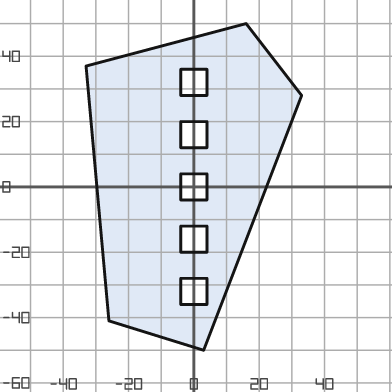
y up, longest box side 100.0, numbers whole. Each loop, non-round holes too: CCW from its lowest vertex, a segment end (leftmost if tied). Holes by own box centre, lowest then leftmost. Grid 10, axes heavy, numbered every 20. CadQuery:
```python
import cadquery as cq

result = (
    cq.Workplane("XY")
    .moveTo(3.0, -50.0)
    .lineTo(33.0, 28.0)
    .lineTo(16.0, 50.0)
    .lineTo(-33.0, 37.0)
    .lineTo(-26.0, -41.0)
    .close()
    .moveTo(-4.0, -36.0)
    .lineTo(4.0, -36.0)
    .lineTo(4.0, -28.0)
    .lineTo(-4.0, -28.0)
    .close()
    .moveTo(-4.0, -20.0)
    .lineTo(4.0, -20.0)
    .lineTo(4.0, -12.0)
    .lineTo(-4.0, -12.0)
    .close()
    .moveTo(-4.0, -4.0)
    .lineTo(4.0, -4.0)
    .lineTo(4.0, 4.0)
    .lineTo(-4.0, 4.0)
    .close()
    .moveTo(-4.0, 12.0)
    .lineTo(4.0, 12.0)
    .lineTo(4.0, 20.0)
    .lineTo(-4.0, 20.0)
    .close()
    .moveTo(-4.0, 28.0)
    .lineTo(4.0, 28.0)
    .lineTo(4.0, 36.0)
    .lineTo(-4.0, 36.0)
    .close()
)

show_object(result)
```